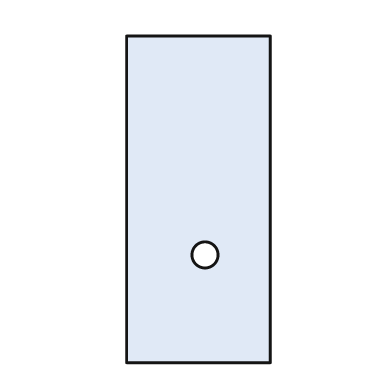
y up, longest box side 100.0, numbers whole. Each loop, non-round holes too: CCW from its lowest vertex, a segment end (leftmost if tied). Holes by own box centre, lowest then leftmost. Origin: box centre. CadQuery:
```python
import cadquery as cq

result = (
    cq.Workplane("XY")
    .moveTo(-22.0, -50.0)
    .lineTo(22.0, -50.0)
    .lineTo(22.0, 50.0)
    .lineTo(-22.0, 50.0)
    .close()
    .moveTo(2.0, -17.0)
    .circle(4.0)
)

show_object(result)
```